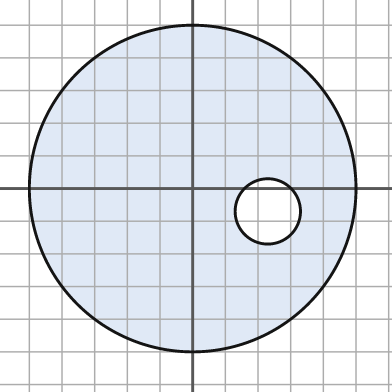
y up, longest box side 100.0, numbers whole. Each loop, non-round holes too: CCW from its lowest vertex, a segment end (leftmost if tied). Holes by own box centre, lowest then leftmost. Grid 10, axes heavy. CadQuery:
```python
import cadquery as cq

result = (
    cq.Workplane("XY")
    .moveTo(0.0, 0.0)
    .circle(50.0)
    .moveTo(23.0, -7.0)
    .circle(10.0)
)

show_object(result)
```